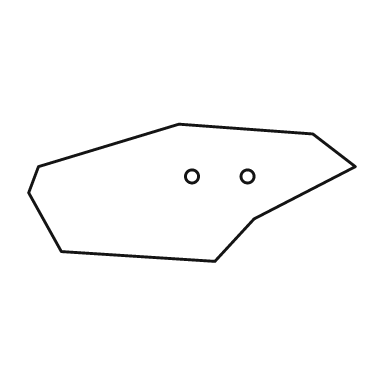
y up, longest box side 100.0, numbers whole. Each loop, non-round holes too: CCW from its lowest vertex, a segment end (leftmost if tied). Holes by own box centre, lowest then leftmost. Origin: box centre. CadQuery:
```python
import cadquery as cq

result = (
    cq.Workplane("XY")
    .moveTo(7.0, -21.0)
    .lineTo(19.0, -8.0)
    .lineTo(50.0, 8.0)
    .lineTo(37.0, 18.0)
    .lineTo(-4.0, 21.0)
    .lineTo(-47.0, 8.0)
    .lineTo(-50.0, 0.0)
    .lineTo(-40.0, -18.0)
    .close()
    .moveTo(0.0, 5.0)
    .circle(2.0)
    .moveTo(17.0, 5.0)
    .circle(2.0)
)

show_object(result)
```